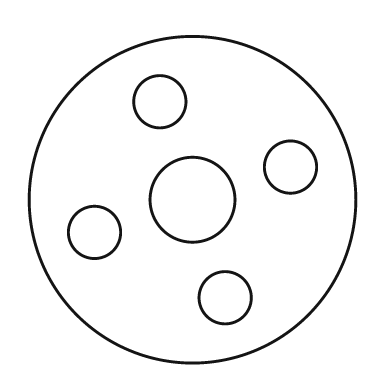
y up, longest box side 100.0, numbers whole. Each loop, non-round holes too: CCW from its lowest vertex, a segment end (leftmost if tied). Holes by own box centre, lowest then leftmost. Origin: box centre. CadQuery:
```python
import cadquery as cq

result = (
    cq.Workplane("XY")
    .moveTo(0.0, 0.0)
    .circle(50.0)
    .moveTo(10.0, -30.0)
    .circle(8.0)
    .moveTo(-30.0, -10.0)
    .circle(8.0)
    .moveTo(0.0, 0.0)
    .circle(13.0)
    .moveTo(30.0, 10.0)
    .circle(8.0)
    .moveTo(-10.0, 30.0)
    .circle(8.0)
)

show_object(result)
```